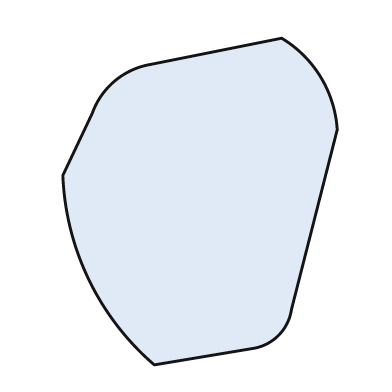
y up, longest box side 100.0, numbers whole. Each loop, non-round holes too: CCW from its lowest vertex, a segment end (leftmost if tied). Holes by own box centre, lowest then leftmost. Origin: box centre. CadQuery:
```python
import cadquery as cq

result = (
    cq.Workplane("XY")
    .moveTo(-14.0, -50.0)
    .lineTo(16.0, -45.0)
    .threePointArc((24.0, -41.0), (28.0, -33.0))
    .lineTo(42.0, 22.0)
    .threePointArc((37.0, 38.0), (25.0, 50.0))
    .lineTo(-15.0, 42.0)
    .threePointArc((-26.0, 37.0), (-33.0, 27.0))
    .lineTo(-42.0, 8.0)
    .threePointArc((-34.0, -24.0), (-14.0, -50.0))
    .close()
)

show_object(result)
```